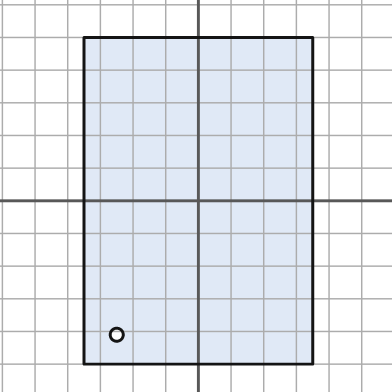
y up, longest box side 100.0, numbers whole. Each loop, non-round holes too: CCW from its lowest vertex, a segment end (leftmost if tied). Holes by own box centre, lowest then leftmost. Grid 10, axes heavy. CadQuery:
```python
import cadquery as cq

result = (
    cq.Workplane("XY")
    .moveTo(-35.0, -50.0)
    .lineTo(35.0, -50.0)
    .lineTo(35.0, 50.0)
    .lineTo(-35.0, 50.0)
    .close()
    .moveTo(-25.0, -41.0)
    .circle(2.0)
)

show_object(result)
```